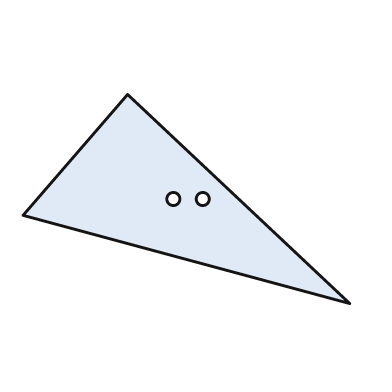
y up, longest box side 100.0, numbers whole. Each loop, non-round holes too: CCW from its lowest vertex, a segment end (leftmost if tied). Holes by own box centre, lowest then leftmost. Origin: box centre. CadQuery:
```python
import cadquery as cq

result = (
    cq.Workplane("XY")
    .moveTo(50.0, -32.0)
    .lineTo(-18.0, 32.0)
    .lineTo(-50.0, -5.0)
    .close()
    .moveTo(-4.0, 0.0)
    .circle(2.0)
    .moveTo(5.0, 0.0)
    .circle(2.0)
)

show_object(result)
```